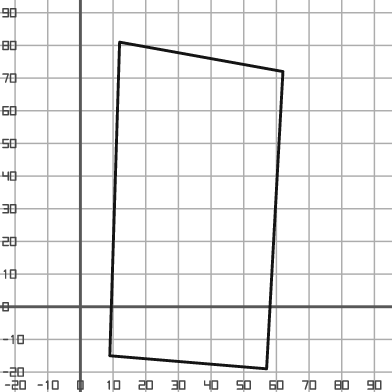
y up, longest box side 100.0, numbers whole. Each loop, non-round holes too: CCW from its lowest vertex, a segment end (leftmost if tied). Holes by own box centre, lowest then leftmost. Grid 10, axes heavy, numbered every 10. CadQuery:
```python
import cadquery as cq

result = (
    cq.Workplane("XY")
    .moveTo(57.0, -19.0)
    .lineTo(62.0, 72.0)
    .lineTo(12.0, 81.0)
    .lineTo(9.0, -15.0)
    .close()
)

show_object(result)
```